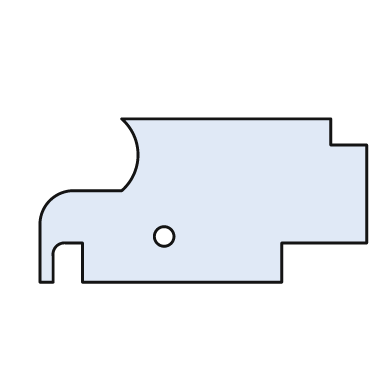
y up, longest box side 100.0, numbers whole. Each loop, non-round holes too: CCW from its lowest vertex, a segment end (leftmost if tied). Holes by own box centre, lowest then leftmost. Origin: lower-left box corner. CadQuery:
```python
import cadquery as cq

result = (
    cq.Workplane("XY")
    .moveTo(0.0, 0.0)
    .lineTo(4.0, 0.0)
    .lineTo(4.0, 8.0)
    .threePointArc((5.0, 11.0), (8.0, 12.0))
    .lineTo(13.0, 12.0)
    .lineTo(13.0, 0.0)
    .lineTo(74.0, 0.0)
    .lineTo(74.0, 12.0)
    .lineTo(100.0, 12.0)
    .lineTo(100.0, 42.0)
    .lineTo(89.0, 42.0)
    .lineTo(89.0, 50.0)
    .lineTo(25.0, 50.0)
    .threePointArc((30.0, 39.0), (25.0, 28.0))
    .lineTo(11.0, 28.0)
    .threePointArc((3.0, 25.0), (0.0, 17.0))
    .close()
    .moveTo(38.0, 14.0)
    .circle(3.0)
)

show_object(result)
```